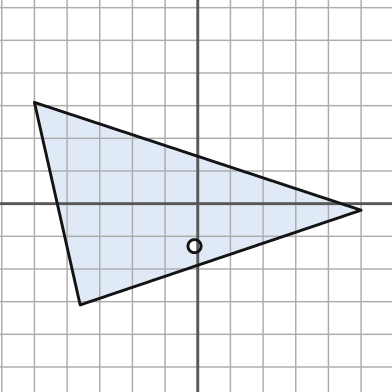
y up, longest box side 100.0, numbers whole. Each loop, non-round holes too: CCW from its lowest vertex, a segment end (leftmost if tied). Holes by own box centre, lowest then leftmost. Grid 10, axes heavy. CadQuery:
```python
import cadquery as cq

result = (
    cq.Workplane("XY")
    .moveTo(-36.0, -31.0)
    .lineTo(50.0, -2.0)
    .lineTo(-50.0, 31.0)
    .close()
    .moveTo(-1.0, -13.0)
    .circle(2.0)
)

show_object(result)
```